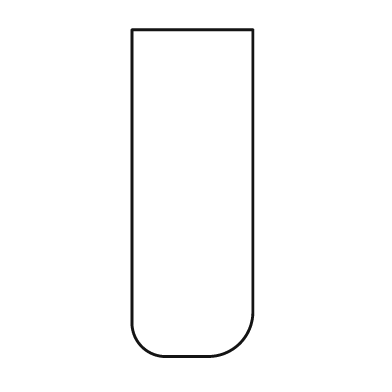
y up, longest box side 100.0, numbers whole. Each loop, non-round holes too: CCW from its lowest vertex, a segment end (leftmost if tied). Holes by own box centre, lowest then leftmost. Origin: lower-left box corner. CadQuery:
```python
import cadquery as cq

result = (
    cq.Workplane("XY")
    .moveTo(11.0, 0.0)
    .lineTo(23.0, 0.0)
    .threePointArc((33.0, 4.0), (37.0, 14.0))
    .lineTo(37.0, 100.0)
    .lineTo(0.0, 100.0)
    .lineTo(0.0, 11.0)
    .threePointArc((3.0, 3.0), (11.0, 0.0))
    .close()
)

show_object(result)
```